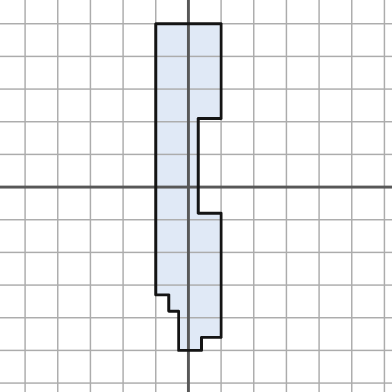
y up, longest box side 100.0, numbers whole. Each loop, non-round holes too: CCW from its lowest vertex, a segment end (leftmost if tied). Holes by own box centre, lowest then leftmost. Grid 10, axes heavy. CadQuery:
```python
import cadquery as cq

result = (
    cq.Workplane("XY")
    .moveTo(-3.0, -50.0)
    .lineTo(4.0, -50.0)
    .lineTo(4.0, -46.0)
    .lineTo(10.0, -46.0)
    .lineTo(10.0, -8.0)
    .lineTo(3.0, -8.0)
    .lineTo(3.0, 21.0)
    .lineTo(10.0, 21.0)
    .lineTo(10.0, 50.0)
    .lineTo(-10.0, 50.0)
    .lineTo(-10.0, -33.0)
    .lineTo(-6.0, -33.0)
    .lineTo(-6.0, -38.0)
    .lineTo(-3.0, -38.0)
    .close()
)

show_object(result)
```